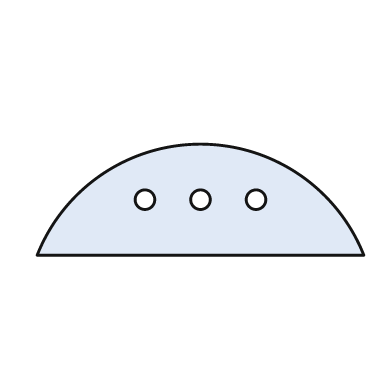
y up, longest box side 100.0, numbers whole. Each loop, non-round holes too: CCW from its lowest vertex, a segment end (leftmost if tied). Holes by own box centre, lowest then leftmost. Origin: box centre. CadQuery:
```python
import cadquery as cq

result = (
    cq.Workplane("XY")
    .moveTo(-50.0, -17.0)
    .lineTo(50.0, -17.0)
    .threePointArc((0.0, 17.0), (-50.0, -17.0))
    .close()
    .moveTo(-17.0, 0.0)
    .circle(3.0)
    .moveTo(0.0, 0.0)
    .circle(3.0)
    .moveTo(17.0, 0.0)
    .circle(3.0)
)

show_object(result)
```